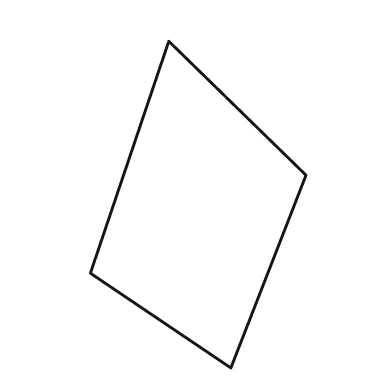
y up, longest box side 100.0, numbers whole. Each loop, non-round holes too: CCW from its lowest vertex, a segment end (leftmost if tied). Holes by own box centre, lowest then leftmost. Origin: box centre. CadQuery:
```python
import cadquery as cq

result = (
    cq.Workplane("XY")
    .moveTo(10.0, -50.0)
    .lineTo(33.0, 9.0)
    .lineTo(-9.0, 50.0)
    .lineTo(-33.0, -21.0)
    .close()
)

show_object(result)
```